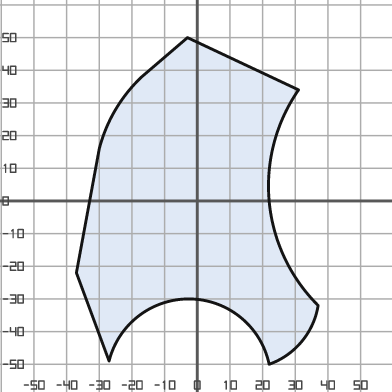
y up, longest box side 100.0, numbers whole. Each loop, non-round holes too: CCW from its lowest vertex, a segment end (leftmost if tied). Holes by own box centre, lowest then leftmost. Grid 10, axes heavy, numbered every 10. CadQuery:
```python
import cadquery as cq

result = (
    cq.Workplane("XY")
    .moveTo(22.0, -50.0)
    .threePointArc((32.0, -43.0), (37.0, -32.0))
    .threePointArc((22.0, 0.0), (31.0, 34.0))
    .lineTo(-3.0, 50.0)
    .lineTo(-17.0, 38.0)
    .threePointArc((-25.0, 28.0), (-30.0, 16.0))
    .lineTo(-37.0, -22.0)
    .lineTo(-27.0, -49.0)
    .threePointArc((-2.0, -30.0), (22.0, -50.0))
    .close()
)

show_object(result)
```